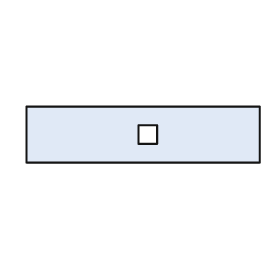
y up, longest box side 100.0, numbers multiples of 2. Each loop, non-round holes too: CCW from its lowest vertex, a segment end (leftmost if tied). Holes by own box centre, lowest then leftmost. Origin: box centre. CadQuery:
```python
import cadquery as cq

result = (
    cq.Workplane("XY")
    .moveTo(-50.0, -12.0)
    .lineTo(50.0, -12.0)
    .lineTo(50.0, 12.0)
    .lineTo(-50.0, 12.0)
    .close()
    .moveTo(-2.0, -4.0)
    .lineTo(6.0, -4.0)
    .lineTo(6.0, 4.0)
    .lineTo(-2.0, 4.0)
    .close()
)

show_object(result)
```